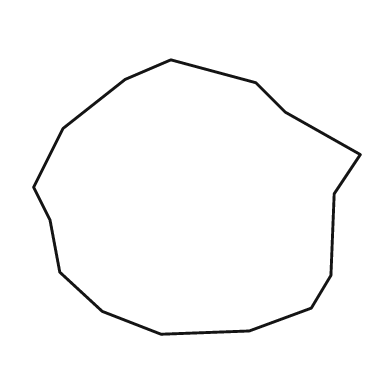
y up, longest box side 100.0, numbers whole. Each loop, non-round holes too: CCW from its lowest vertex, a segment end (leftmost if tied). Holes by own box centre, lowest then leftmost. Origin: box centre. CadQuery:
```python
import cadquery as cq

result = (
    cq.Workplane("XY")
    .moveTo(-11.0, -42.0)
    .lineTo(16.0, -41.0)
    .lineTo(35.0, -34.0)
    .lineTo(41.0, -24.0)
    .lineTo(42.0, 1.0)
    .lineTo(50.0, 13.0)
    .lineTo(27.0, 26.0)
    .lineTo(18.0, 35.0)
    .lineTo(-8.0, 42.0)
    .lineTo(-22.0, 36.0)
    .lineTo(-41.0, 21.0)
    .lineTo(-50.0, 3.0)
    .lineTo(-45.0, -7.0)
    .lineTo(-42.0, -23.0)
    .lineTo(-29.0, -35.0)
    .close()
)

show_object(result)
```